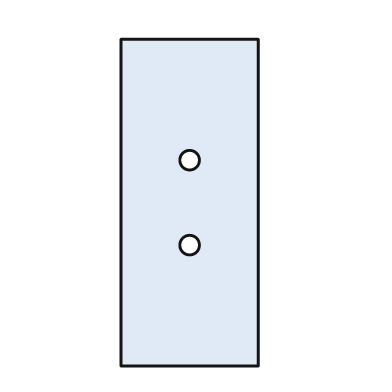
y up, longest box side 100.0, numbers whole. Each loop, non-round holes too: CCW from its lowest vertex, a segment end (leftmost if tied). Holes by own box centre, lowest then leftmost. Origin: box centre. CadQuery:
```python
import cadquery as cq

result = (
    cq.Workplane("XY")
    .moveTo(-21.0, -50.0)
    .lineTo(21.0, -50.0)
    .lineTo(21.0, 50.0)
    .lineTo(-21.0, 50.0)
    .close()
    .moveTo(0.0, -13.0)
    .circle(3.0)
    .moveTo(0.0, 13.0)
    .circle(3.0)
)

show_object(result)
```